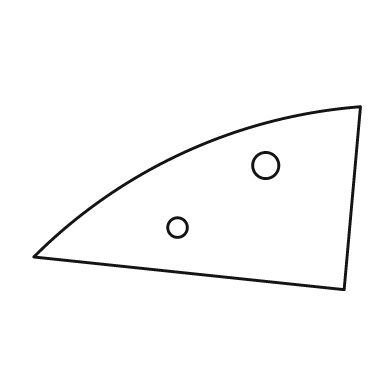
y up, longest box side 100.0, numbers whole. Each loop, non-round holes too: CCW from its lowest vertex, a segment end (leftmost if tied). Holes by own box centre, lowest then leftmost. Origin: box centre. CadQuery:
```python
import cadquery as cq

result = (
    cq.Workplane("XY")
    .moveTo(45.0, -28.0)
    .lineTo(50.0, 28.0)
    .threePointArc((-4.0, 14.0), (-50.0, -18.0))
    .close()
    .moveTo(-6.0, -9.0)
    .circle(3.0)
    .moveTo(21.0, 10.0)
    .circle(4.0)
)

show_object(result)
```